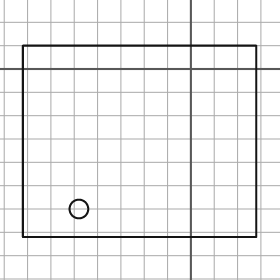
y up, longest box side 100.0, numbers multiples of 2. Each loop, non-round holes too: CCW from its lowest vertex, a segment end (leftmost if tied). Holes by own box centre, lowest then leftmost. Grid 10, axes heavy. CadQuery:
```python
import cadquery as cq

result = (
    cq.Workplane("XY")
    .moveTo(-72.0, -72.0)
    .lineTo(28.0, -72.0)
    .lineTo(28.0, 10.0)
    .lineTo(-72.0, 10.0)
    .close()
    .moveTo(-48.0, -60.0)
    .circle(4.0)
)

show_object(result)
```